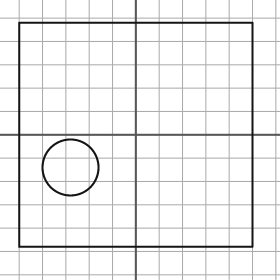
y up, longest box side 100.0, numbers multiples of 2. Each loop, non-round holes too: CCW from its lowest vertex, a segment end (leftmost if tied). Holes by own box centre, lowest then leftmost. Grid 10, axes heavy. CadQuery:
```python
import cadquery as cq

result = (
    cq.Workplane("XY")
    .moveTo(-50.0, -48.0)
    .lineTo(50.0, -48.0)
    .lineTo(50.0, 48.0)
    .lineTo(-50.0, 48.0)
    .close()
    .moveTo(-28.0, -14.0)
    .circle(12.0)
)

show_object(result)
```